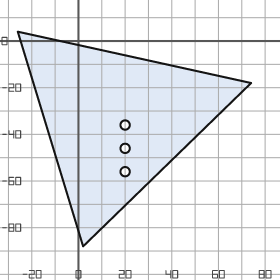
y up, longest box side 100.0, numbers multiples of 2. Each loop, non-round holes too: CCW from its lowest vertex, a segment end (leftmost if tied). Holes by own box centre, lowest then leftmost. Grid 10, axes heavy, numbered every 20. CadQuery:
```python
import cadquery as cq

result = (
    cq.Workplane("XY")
    .moveTo(2.0, -88.0)
    .lineTo(74.0, -18.0)
    .lineTo(-26.0, 4.0)
    .close()
    .moveTo(20.0, -56.0)
    .circle(2.0)
    .moveTo(20.0, -46.0)
    .circle(2.0)
    .moveTo(20.0, -36.0)
    .circle(2.0)
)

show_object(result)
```